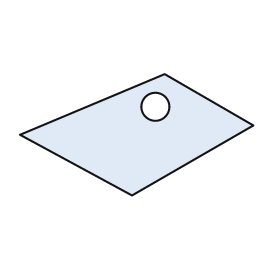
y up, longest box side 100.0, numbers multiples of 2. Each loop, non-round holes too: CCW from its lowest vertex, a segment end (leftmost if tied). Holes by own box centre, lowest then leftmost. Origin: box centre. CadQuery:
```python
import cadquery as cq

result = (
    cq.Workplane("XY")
    .moveTo(-2.0, -26.0)
    .lineTo(50.0, 4.0)
    .lineTo(12.0, 26.0)
    .lineTo(-50.0, 0.0)
    .close()
    .moveTo(8.0, 12.0)
    .circle(6.0)
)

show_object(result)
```